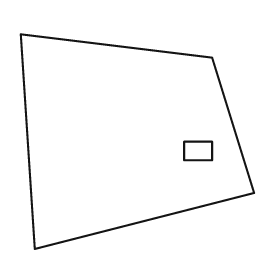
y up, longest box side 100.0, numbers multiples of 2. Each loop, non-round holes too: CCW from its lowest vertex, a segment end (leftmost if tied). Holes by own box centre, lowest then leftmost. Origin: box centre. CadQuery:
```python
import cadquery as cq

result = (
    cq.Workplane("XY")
    .moveTo(-44.0, -46.0)
    .lineTo(50.0, -22.0)
    .lineTo(32.0, 36.0)
    .lineTo(-50.0, 46.0)
    .close()
    .moveTo(20.0, -8.0)
    .lineTo(32.0, -8.0)
    .lineTo(32.0, 0.0)
    .lineTo(20.0, 0.0)
    .close()
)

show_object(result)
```